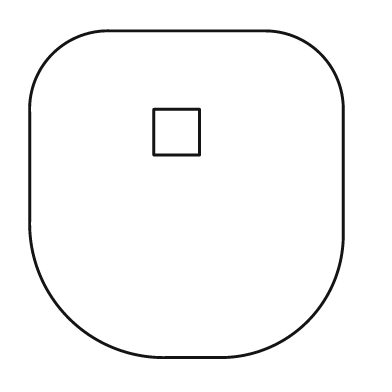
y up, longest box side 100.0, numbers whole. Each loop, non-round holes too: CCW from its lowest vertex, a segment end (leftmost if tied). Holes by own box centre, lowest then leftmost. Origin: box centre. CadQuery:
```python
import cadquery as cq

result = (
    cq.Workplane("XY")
    .moveTo(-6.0, -50.0)
    .lineTo(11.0, -50.0)
    .threePointArc((37.0, -39.0), (48.0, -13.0))
    .lineTo(48.0, 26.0)
    .threePointArc((41.0, 43.0), (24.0, 50.0))
    .lineTo(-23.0, 50.0)
    .threePointArc((-41.0, 43.0), (-48.0, 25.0))
    .lineTo(-48.0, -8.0)
    .threePointArc((-36.0, -38.0), (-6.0, -50.0))
    .close()
    .moveTo(-10.0, 12.0)
    .lineTo(4.0, 12.0)
    .lineTo(4.0, 26.0)
    .lineTo(-10.0, 26.0)
    .close()
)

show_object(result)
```